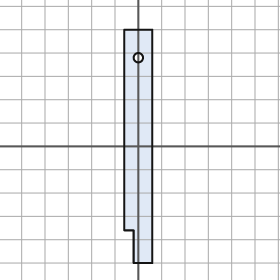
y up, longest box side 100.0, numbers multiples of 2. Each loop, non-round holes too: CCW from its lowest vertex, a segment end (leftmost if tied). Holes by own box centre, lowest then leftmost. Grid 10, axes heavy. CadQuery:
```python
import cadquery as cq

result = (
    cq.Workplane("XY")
    .moveTo(-2.0, -50.0)
    .lineTo(6.0, -50.0)
    .lineTo(6.0, 50.0)
    .lineTo(-6.0, 50.0)
    .lineTo(-6.0, -36.0)
    .lineTo(-2.0, -36.0)
    .close()
    .moveTo(0.0, 38.0)
    .circle(2.0)
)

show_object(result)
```